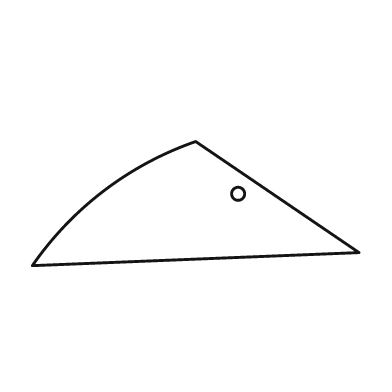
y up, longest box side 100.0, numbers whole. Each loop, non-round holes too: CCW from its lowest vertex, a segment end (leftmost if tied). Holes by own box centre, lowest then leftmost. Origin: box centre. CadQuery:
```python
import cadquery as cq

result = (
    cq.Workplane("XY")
    .moveTo(-50.0, -19.0)
    .lineTo(50.0, -15.0)
    .lineTo(0.0, 19.0)
    .threePointArc((-28.0, 4.0), (-50.0, -19.0))
    .close()
    .moveTo(13.0, 3.0)
    .circle(2.0)
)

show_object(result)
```